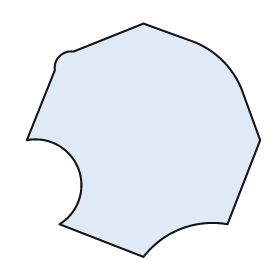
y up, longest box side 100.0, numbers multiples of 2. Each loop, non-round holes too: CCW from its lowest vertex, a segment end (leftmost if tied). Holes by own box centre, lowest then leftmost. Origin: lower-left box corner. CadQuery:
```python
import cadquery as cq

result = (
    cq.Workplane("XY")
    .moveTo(50.0, 0.0)
    .threePointArc((66.0, 12.0), (86.0, 14.0))
    .lineTo(100.0, 50.0)
    .lineTo(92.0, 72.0)
    .threePointArc((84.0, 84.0), (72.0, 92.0))
    .lineTo(50.0, 100.0)
    .lineTo(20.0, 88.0)
    .threePointArc((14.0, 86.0), (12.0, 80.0))
    .lineTo(0.0, 50.0)
    .threePointArc((22.0, 38.0), (14.0, 14.0))
    .close()
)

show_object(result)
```